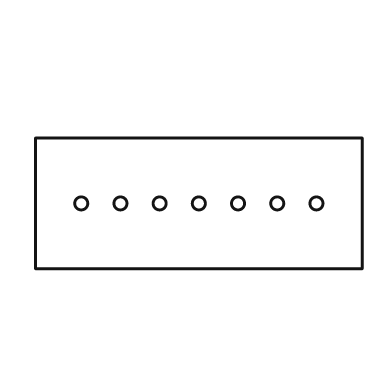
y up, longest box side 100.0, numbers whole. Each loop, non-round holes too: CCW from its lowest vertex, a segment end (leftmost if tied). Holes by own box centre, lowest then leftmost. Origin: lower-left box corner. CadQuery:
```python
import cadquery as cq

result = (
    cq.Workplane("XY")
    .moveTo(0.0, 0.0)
    .lineTo(100.0, 0.0)
    .lineTo(100.0, 40.0)
    .lineTo(0.0, 40.0)
    .close()
    .moveTo(14.0, 20.0)
    .circle(2.0)
    .moveTo(26.0, 20.0)
    .circle(2.0)
    .moveTo(38.0, 20.0)
    .circle(2.0)
    .moveTo(50.0, 20.0)
    .circle(2.0)
    .moveTo(62.0, 20.0)
    .circle(2.0)
    .moveTo(74.0, 20.0)
    .circle(2.0)
    .moveTo(86.0, 20.0)
    .circle(2.0)
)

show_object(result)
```